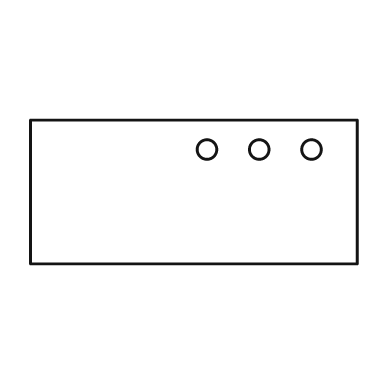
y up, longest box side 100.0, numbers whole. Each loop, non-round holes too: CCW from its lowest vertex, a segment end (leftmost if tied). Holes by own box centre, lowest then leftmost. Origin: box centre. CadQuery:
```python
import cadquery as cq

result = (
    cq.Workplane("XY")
    .moveTo(-50.0, -22.0)
    .lineTo(50.0, -22.0)
    .lineTo(50.0, 22.0)
    .lineTo(-50.0, 22.0)
    .close()
    .moveTo(4.0, 13.0)
    .circle(3.0)
    .moveTo(20.0, 13.0)
    .circle(3.0)
    .moveTo(36.0, 13.0)
    .circle(3.0)
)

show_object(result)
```